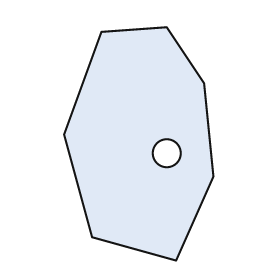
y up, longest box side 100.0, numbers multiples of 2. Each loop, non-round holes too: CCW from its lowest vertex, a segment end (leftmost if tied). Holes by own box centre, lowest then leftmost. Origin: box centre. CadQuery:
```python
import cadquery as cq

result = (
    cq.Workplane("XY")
    .moveTo(16.0, -50.0)
    .lineTo(32.0, -14.0)
    .lineTo(28.0, 26.0)
    .lineTo(12.0, 50.0)
    .lineTo(-16.0, 48.0)
    .lineTo(-32.0, 4.0)
    .lineTo(-20.0, -40.0)
    .close()
    .moveTo(12.0, -4.0)
    .circle(6.0)
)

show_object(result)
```